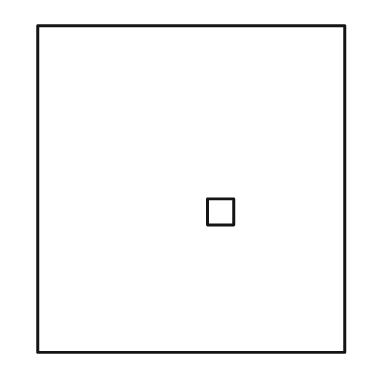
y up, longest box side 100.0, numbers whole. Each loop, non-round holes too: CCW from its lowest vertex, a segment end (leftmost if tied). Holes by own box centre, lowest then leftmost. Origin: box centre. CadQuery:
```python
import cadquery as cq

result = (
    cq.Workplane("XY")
    .moveTo(-47.0, -50.0)
    .lineTo(47.0, -50.0)
    .lineTo(47.0, 50.0)
    .lineTo(-47.0, 50.0)
    .close()
    .moveTo(5.0, -11.0)
    .lineTo(13.0, -11.0)
    .lineTo(13.0, -3.0)
    .lineTo(5.0, -3.0)
    .close()
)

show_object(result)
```